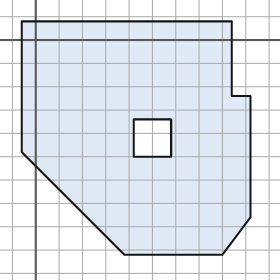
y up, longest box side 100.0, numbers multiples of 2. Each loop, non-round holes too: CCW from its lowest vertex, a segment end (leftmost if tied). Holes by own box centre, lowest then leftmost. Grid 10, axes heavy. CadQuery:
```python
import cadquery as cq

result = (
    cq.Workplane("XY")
    .moveTo(38.0, -92.0)
    .lineTo(80.0, -92.0)
    .lineTo(92.0, -76.0)
    .lineTo(92.0, -24.0)
    .lineTo(84.0, -24.0)
    .lineTo(84.0, 8.0)
    .lineTo(-6.0, 8.0)
    .lineTo(-6.0, -48.0)
    .close()
    .moveTo(42.0, -50.0)
    .lineTo(58.0, -50.0)
    .lineTo(58.0, -34.0)
    .lineTo(42.0, -34.0)
    .close()
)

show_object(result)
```